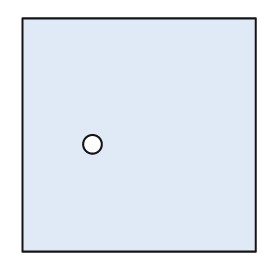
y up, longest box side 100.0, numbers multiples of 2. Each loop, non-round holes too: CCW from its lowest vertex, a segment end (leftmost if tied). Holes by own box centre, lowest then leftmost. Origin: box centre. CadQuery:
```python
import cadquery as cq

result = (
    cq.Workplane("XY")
    .moveTo(-50.0, -50.0)
    .lineTo(50.0, -50.0)
    .lineTo(50.0, 50.0)
    .lineTo(-50.0, 50.0)
    .close()
    .moveTo(-20.0, -4.0)
    .circle(4.0)
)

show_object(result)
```